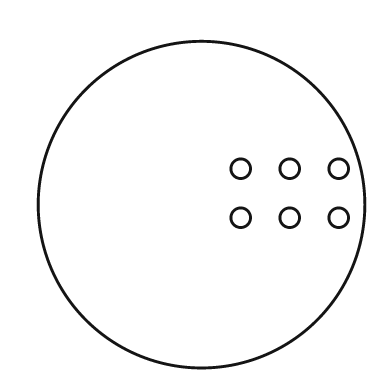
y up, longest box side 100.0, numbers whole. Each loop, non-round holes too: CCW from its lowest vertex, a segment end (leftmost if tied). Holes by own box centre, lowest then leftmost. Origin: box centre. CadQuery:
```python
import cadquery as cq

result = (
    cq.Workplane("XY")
    .moveTo(0.0, 0.0)
    .circle(50.0)
    .moveTo(12.0, -4.0)
    .circle(3.0)
    .moveTo(27.0, -4.0)
    .circle(3.0)
    .moveTo(42.0, -4.0)
    .circle(3.0)
    .moveTo(12.0, 11.0)
    .circle(3.0)
    .moveTo(27.0, 11.0)
    .circle(3.0)
    .moveTo(42.0, 11.0)
    .circle(3.0)
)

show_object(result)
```